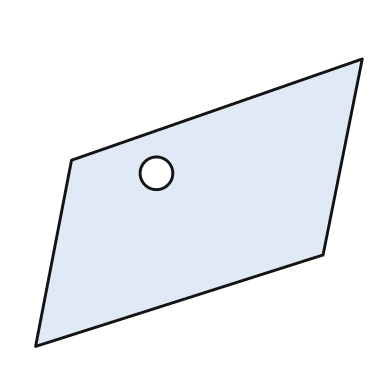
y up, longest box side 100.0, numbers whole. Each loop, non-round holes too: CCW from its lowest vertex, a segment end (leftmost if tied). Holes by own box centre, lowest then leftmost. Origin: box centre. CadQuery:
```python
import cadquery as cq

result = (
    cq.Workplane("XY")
    .moveTo(-50.0, -44.0)
    .lineTo(38.0, -16.0)
    .lineTo(50.0, 44.0)
    .lineTo(-39.0, 13.0)
    .close()
    .moveTo(-13.0, 9.0)
    .circle(5.0)
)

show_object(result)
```